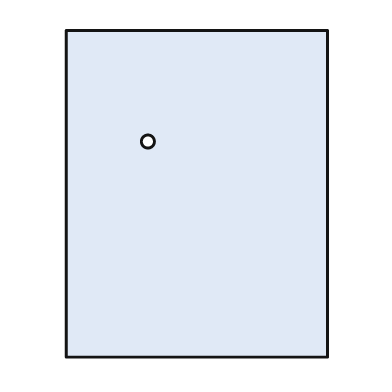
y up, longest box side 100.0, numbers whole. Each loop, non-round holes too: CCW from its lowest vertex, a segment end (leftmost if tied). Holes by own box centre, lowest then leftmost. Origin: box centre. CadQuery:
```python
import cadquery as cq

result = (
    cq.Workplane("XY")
    .moveTo(-40.0, -50.0)
    .lineTo(40.0, -50.0)
    .lineTo(40.0, 50.0)
    .lineTo(-40.0, 50.0)
    .close()
    .moveTo(-15.0, 16.0)
    .circle(2.0)
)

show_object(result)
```